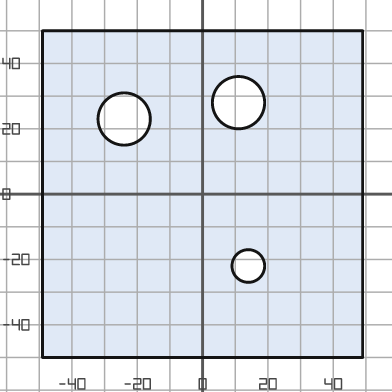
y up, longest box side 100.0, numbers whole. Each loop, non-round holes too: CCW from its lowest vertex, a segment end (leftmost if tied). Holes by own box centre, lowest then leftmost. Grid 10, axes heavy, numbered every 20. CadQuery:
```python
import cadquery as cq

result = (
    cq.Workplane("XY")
    .moveTo(-49.0, -50.0)
    .lineTo(49.0, -50.0)
    .lineTo(49.0, 50.0)
    .lineTo(-49.0, 50.0)
    .close()
    .moveTo(14.0, -22.0)
    .circle(5.0)
    .moveTo(-24.0, 23.0)
    .circle(8.0)
    .moveTo(11.0, 28.0)
    .circle(8.0)
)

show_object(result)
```